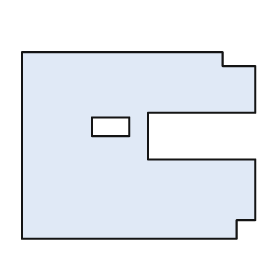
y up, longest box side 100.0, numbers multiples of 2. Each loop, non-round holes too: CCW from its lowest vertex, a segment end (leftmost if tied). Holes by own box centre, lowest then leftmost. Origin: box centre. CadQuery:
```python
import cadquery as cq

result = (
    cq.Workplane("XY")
    .moveTo(-50.0, -40.0)
    .lineTo(42.0, -40.0)
    .lineTo(42.0, -32.0)
    .lineTo(50.0, -32.0)
    .lineTo(50.0, -6.0)
    .lineTo(4.0, -6.0)
    .lineTo(4.0, 14.0)
    .lineTo(50.0, 14.0)
    .lineTo(50.0, 34.0)
    .lineTo(36.0, 34.0)
    .lineTo(36.0, 40.0)
    .lineTo(-50.0, 40.0)
    .close()
    .moveTo(-20.0, 4.0)
    .lineTo(-4.0, 4.0)
    .lineTo(-4.0, 12.0)
    .lineTo(-20.0, 12.0)
    .close()
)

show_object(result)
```